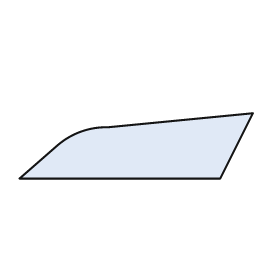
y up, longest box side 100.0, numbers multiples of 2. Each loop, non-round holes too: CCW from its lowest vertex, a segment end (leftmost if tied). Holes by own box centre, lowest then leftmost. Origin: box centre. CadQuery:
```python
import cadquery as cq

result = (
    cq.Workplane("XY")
    .moveTo(-50.0, -14.0)
    .lineTo(36.0, -14.0)
    .lineTo(50.0, 14.0)
    .lineTo(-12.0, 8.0)
    .threePointArc((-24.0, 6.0), (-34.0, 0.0))
    .close()
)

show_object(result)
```